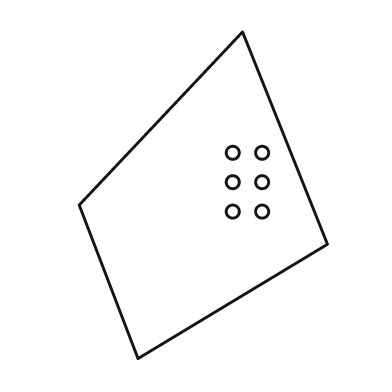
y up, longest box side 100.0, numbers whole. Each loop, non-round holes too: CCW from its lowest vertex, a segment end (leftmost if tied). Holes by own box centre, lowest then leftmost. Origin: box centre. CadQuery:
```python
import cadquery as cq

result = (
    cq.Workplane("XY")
    .moveTo(-20.0, -50.0)
    .lineTo(38.0, -15.0)
    .lineTo(12.0, 50.0)
    .lineTo(-38.0, -3.0)
    .close()
    .moveTo(9.0, -5.0)
    .circle(2.0)
    .moveTo(18.0, -5.0)
    .circle(2.0)
    .moveTo(9.0, 4.0)
    .circle(2.0)
    .moveTo(18.0, 4.0)
    .circle(2.0)
    .moveTo(9.0, 13.0)
    .circle(2.0)
    .moveTo(18.0, 13.0)
    .circle(2.0)
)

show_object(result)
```